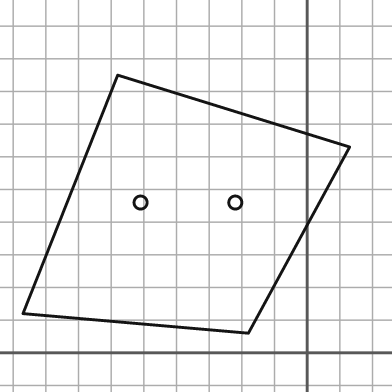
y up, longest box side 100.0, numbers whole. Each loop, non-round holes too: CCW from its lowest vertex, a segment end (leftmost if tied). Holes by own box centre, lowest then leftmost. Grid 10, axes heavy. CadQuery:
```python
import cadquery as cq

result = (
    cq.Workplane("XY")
    .moveTo(-18.0, 6.0)
    .lineTo(13.0, 63.0)
    .lineTo(-58.0, 85.0)
    .lineTo(-87.0, 12.0)
    .close()
    .moveTo(-51.0, 46.0)
    .circle(2.0)
    .moveTo(-22.0, 46.0)
    .circle(2.0)
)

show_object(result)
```